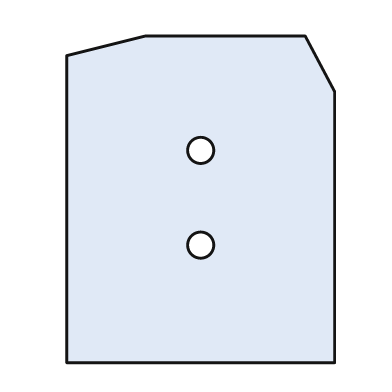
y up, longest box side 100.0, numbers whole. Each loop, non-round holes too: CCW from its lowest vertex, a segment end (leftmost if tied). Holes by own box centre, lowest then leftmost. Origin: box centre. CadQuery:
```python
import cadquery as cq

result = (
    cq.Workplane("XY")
    .moveTo(-41.0, -50.0)
    .lineTo(41.0, -50.0)
    .lineTo(41.0, 33.0)
    .lineTo(32.0, 50.0)
    .lineTo(-17.0, 50.0)
    .lineTo(-41.0, 44.0)
    .close()
    .moveTo(0.0, -14.0)
    .circle(4.0)
    .moveTo(0.0, 15.0)
    .circle(4.0)
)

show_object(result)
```